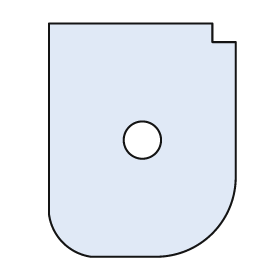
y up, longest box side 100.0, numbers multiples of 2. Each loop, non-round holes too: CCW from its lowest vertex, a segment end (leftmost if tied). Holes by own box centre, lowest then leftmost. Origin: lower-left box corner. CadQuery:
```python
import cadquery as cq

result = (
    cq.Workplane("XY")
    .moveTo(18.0, 0.0)
    .lineTo(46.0, 0.0)
    .threePointArc((70.0, 10.0), (80.0, 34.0))
    .lineTo(80.0, 92.0)
    .lineTo(70.0, 92.0)
    .lineTo(70.0, 100.0)
    .lineTo(0.0, 100.0)
    .lineTo(0.0, 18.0)
    .threePointArc((6.0, 6.0), (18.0, 0.0))
    .close()
    .moveTo(40.0, 50.0)
    .circle(8.0)
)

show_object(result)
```